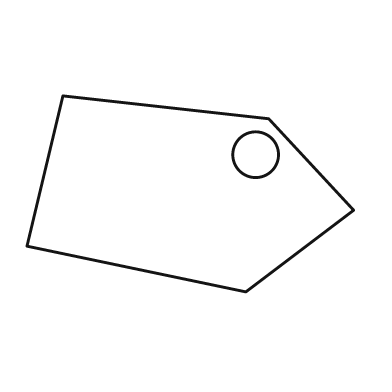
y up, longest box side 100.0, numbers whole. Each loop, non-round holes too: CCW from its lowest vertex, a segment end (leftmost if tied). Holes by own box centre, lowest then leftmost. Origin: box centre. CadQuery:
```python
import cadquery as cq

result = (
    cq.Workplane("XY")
    .moveTo(17.0, -30.0)
    .lineTo(50.0, -5.0)
    .lineTo(24.0, 23.0)
    .lineTo(-39.0, 30.0)
    .lineTo(-50.0, -16.0)
    .close()
    .moveTo(20.0, 12.0)
    .circle(7.0)
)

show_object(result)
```